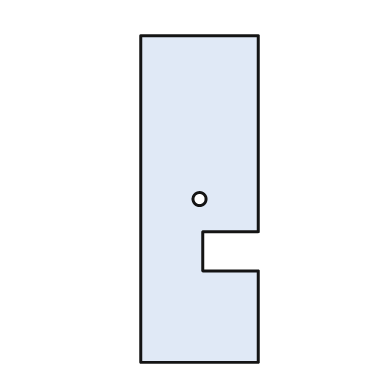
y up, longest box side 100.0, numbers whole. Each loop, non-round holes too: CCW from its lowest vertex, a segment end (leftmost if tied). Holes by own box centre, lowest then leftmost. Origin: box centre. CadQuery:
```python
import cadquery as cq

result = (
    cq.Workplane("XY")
    .moveTo(-18.0, -50.0)
    .lineTo(18.0, -50.0)
    .lineTo(18.0, -22.0)
    .lineTo(1.0, -22.0)
    .lineTo(1.0, -10.0)
    .lineTo(18.0, -10.0)
    .lineTo(18.0, 50.0)
    .lineTo(-18.0, 50.0)
    .close()
    .moveTo(0.0, 0.0)
    .circle(2.0)
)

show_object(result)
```